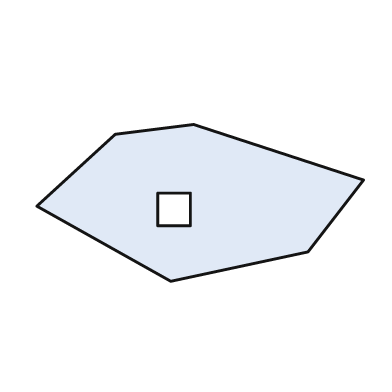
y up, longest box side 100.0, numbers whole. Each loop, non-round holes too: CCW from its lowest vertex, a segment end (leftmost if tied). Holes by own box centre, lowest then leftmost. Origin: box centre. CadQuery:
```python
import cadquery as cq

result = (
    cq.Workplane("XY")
    .moveTo(-9.0, -24.0)
    .lineTo(33.0, -15.0)
    .lineTo(50.0, 7.0)
    .lineTo(-2.0, 24.0)
    .lineTo(-26.0, 21.0)
    .lineTo(-50.0, -1.0)
    .close()
    .moveTo(-13.0, -7.0)
    .lineTo(-3.0, -7.0)
    .lineTo(-3.0, 3.0)
    .lineTo(-13.0, 3.0)
    .close()
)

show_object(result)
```